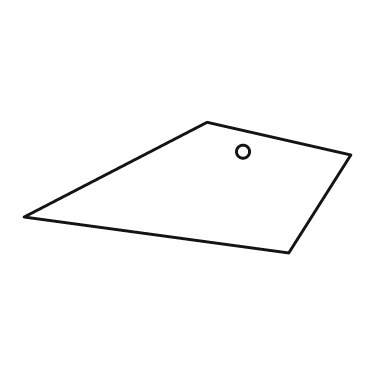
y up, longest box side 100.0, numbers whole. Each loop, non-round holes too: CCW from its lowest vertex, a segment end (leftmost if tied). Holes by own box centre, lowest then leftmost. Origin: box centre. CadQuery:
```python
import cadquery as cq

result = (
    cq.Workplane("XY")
    .moveTo(31.0, -20.0)
    .lineTo(50.0, 10.0)
    .lineTo(6.0, 20.0)
    .lineTo(-50.0, -9.0)
    .close()
    .moveTo(17.0, 11.0)
    .circle(2.0)
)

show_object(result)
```